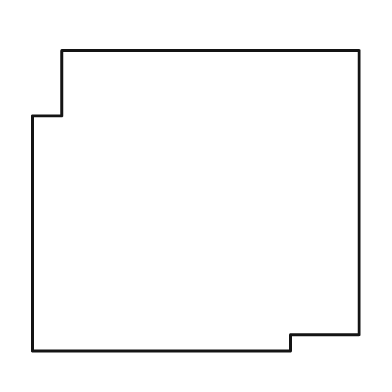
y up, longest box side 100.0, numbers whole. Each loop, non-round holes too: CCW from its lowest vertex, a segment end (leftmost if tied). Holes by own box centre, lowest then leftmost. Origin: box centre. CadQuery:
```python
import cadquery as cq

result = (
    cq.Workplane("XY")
    .moveTo(-50.0, -46.0)
    .lineTo(29.0, -46.0)
    .lineTo(29.0, -41.0)
    .lineTo(50.0, -41.0)
    .lineTo(50.0, 46.0)
    .lineTo(-41.0, 46.0)
    .lineTo(-41.0, 26.0)
    .lineTo(-50.0, 26.0)
    .close()
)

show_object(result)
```